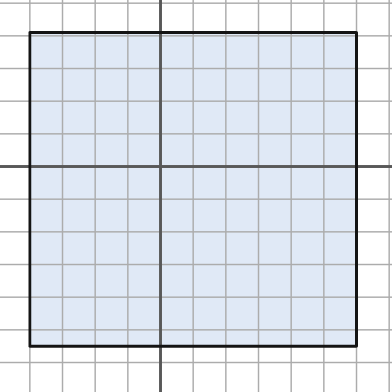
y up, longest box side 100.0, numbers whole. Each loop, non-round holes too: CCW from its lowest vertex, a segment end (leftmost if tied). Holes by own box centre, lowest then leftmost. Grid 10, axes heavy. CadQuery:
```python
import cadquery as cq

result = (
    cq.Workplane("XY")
    .moveTo(-40.0, -55.0)
    .lineTo(60.0, -55.0)
    .lineTo(60.0, 41.0)
    .lineTo(-40.0, 41.0)
    .close()
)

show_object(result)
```